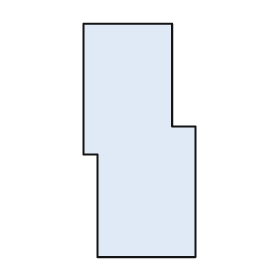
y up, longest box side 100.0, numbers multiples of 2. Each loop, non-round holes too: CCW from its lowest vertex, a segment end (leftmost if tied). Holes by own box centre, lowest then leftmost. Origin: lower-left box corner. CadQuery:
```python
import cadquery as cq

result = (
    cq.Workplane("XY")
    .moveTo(6.0, 0.0)
    .lineTo(48.0, 0.0)
    .lineTo(48.0, 56.0)
    .lineTo(38.0, 56.0)
    .lineTo(38.0, 100.0)
    .lineTo(0.0, 100.0)
    .lineTo(0.0, 44.0)
    .lineTo(6.0, 44.0)
    .close()
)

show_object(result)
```